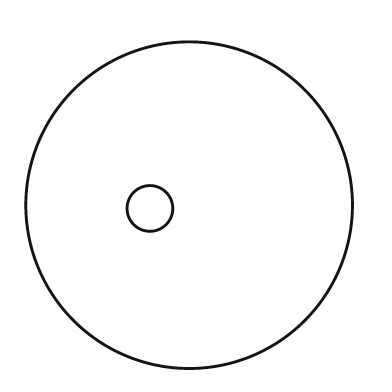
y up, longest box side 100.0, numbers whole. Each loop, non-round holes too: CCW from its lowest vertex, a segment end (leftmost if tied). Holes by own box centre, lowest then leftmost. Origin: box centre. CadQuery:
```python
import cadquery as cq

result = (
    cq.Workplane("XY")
    .moveTo(0.0, 0.0)
    .circle(50.0)
    .moveTo(-12.0, -1.0)
    .circle(7.0)
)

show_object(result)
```